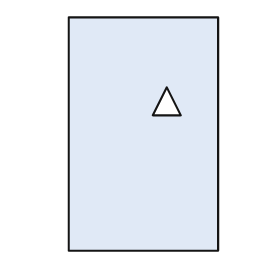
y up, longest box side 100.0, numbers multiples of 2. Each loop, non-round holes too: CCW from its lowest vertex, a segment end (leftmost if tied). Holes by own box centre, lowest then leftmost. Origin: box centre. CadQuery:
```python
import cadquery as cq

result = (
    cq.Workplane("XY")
    .moveTo(-32.0, -50.0)
    .lineTo(32.0, -50.0)
    .lineTo(32.0, 50.0)
    .lineTo(-32.0, 50.0)
    .close()
    .moveTo(4.0, 8.0)
    .lineTo(16.0, 8.0)
    .lineTo(10.0, 20.0)
    .close()
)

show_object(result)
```